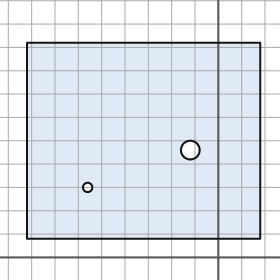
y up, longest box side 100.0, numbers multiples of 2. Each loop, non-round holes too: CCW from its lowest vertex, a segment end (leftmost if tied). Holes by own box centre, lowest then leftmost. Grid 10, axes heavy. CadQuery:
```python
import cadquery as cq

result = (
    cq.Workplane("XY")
    .moveTo(-82.0, 8.0)
    .lineTo(18.0, 8.0)
    .lineTo(18.0, 92.0)
    .lineTo(-82.0, 92.0)
    .close()
    .moveTo(-56.0, 30.0)
    .circle(2.0)
    .moveTo(-12.0, 46.0)
    .circle(4.0)
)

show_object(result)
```